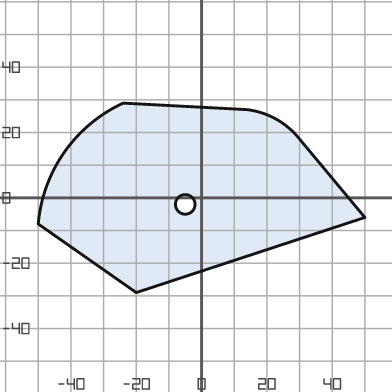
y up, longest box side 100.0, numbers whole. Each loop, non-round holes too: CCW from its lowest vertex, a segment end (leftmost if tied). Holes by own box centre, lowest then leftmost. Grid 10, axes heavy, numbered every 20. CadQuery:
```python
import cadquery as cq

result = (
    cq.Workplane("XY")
    .moveTo(-20.0, -29.0)
    .lineTo(50.0, -6.0)
    .lineTo(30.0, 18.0)
    .threePointArc((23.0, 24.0), (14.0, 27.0))
    .lineTo(-24.0, 29.0)
    .threePointArc((-42.0, 14.0), (-50.0, -8.0))
    .close()
    .moveTo(-5.0, -2.0)
    .circle(3.0)
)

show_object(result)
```